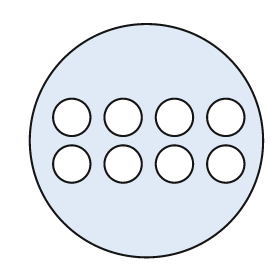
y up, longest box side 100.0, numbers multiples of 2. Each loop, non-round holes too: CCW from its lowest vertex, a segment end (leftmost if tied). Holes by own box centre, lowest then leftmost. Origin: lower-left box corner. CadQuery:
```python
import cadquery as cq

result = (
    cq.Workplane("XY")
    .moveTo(50.0, 50.0)
    .circle(50.0)
    .moveTo(18.0, 40.0)
    .circle(8.0)
    .moveTo(40.0, 40.0)
    .circle(8.0)
    .moveTo(62.0, 40.0)
    .circle(8.0)
    .moveTo(84.0, 40.0)
    .circle(8.0)
    .moveTo(18.0, 60.0)
    .circle(8.0)
    .moveTo(40.0, 60.0)
    .circle(8.0)
    .moveTo(62.0, 60.0)
    .circle(8.0)
    .moveTo(84.0, 60.0)
    .circle(8.0)
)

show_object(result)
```